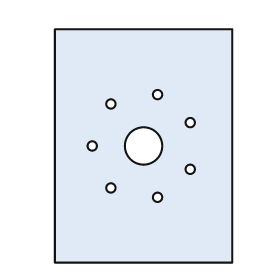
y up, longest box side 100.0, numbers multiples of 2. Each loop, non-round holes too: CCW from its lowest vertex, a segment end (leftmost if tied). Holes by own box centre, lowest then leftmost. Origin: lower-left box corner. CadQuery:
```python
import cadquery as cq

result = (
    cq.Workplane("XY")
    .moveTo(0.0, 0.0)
    .lineTo(76.0, 0.0)
    .lineTo(76.0, 100.0)
    .lineTo(0.0, 100.0)
    .close()
    .moveTo(44.0, 28.0)
    .circle(2.0)
    .moveTo(24.0, 32.0)
    .circle(2.0)
    .moveTo(58.0, 40.0)
    .circle(2.0)
    .moveTo(16.0, 50.0)
    .circle(2.0)
    .moveTo(38.0, 50.0)
    .circle(8.0)
    .moveTo(58.0, 60.0)
    .circle(2.0)
    .moveTo(24.0, 68.0)
    .circle(2.0)
    .moveTo(44.0, 72.0)
    .circle(2.0)
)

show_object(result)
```